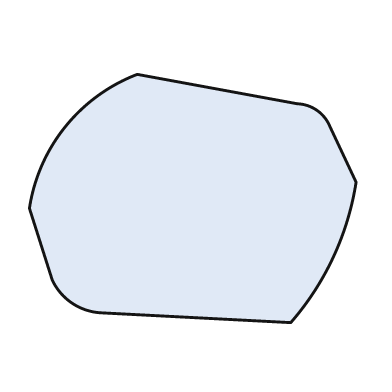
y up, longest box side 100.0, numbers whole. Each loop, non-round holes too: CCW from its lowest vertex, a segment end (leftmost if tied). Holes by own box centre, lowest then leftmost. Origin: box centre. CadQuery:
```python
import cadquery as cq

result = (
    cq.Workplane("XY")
    .moveTo(30.0, -38.0)
    .threePointArc((43.0, -18.0), (50.0, 5.0))
    .lineTo(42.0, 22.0)
    .threePointArc((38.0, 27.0), (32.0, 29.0))
    .lineTo(-17.0, 38.0)
    .threePointArc((-39.0, 22.0), (-50.0, -3.0))
    .lineTo(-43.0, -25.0)
    .threePointArc((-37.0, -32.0), (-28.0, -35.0))
    .close()
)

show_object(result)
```